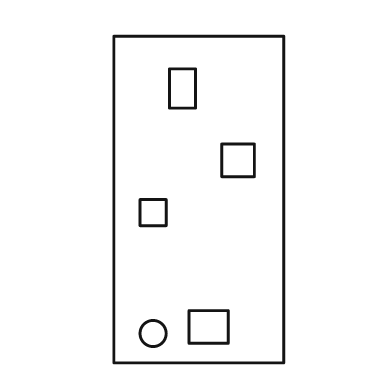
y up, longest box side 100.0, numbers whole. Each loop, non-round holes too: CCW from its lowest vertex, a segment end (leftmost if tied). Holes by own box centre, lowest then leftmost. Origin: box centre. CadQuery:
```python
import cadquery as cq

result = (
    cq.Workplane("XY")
    .moveTo(-26.0, -50.0)
    .lineTo(26.0, -50.0)
    .lineTo(26.0, 50.0)
    .lineTo(-26.0, 50.0)
    .close()
    .moveTo(-14.0, -41.0)
    .circle(4.0)
    .moveTo(-3.0, -44.0)
    .lineTo(9.0, -44.0)
    .lineTo(9.0, -34.0)
    .lineTo(-3.0, -34.0)
    .close()
    .moveTo(-18.0, -8.0)
    .lineTo(-10.0, -8.0)
    .lineTo(-10.0, 0.0)
    .lineTo(-18.0, 0.0)
    .close()
    .moveTo(7.0, 7.0)
    .lineTo(17.0, 7.0)
    .lineTo(17.0, 17.0)
    .lineTo(7.0, 17.0)
    .close()
    .moveTo(-9.0, 28.0)
    .lineTo(-1.0, 28.0)
    .lineTo(-1.0, 40.0)
    .lineTo(-9.0, 40.0)
    .close()
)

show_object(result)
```